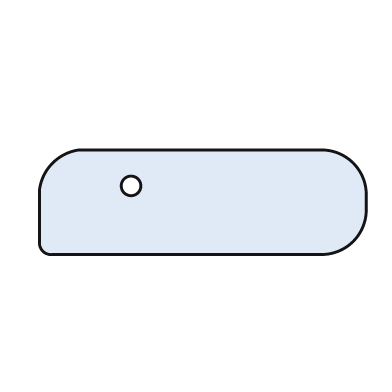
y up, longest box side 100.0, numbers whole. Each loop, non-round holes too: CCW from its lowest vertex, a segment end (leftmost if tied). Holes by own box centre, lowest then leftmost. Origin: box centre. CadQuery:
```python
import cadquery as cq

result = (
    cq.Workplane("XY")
    .moveTo(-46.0, -16.0)
    .lineTo(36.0, -16.0)
    .threePointArc((46.0, -12.0), (50.0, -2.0))
    .lineTo(50.0, 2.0)
    .threePointArc((46.0, 12.0), (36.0, 16.0))
    .lineTo(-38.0, 16.0)
    .threePointArc((-46.0, 12.0), (-50.0, 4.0))
    .lineTo(-50.0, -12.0)
    .threePointArc((-49.0, -15.0), (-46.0, -16.0))
    .close()
    .moveTo(-22.0, 5.0)
    .circle(3.0)
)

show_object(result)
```